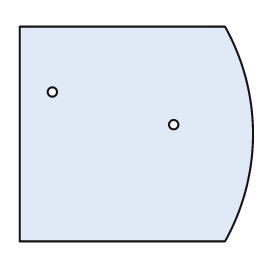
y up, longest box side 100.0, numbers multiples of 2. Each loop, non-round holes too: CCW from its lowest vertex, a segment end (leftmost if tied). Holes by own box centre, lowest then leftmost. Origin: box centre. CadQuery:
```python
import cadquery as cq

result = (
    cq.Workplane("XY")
    .moveTo(-50.0, -46.0)
    .lineTo(38.0, -46.0)
    .threePointArc((50.0, 0.0), (38.0, 46.0))
    .lineTo(-50.0, 46.0)
    .close()
    .moveTo(16.0, 4.0)
    .circle(2.0)
    .moveTo(-36.0, 18.0)
    .circle(2.0)
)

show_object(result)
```